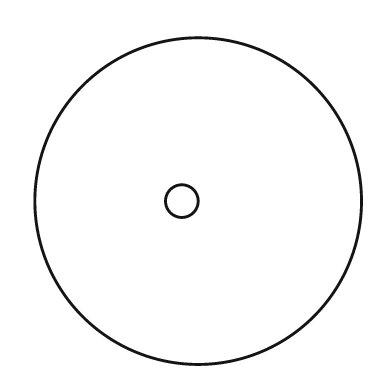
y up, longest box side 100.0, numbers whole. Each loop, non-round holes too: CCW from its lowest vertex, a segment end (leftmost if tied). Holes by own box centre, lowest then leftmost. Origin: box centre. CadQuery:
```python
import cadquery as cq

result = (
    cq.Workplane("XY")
    .moveTo(0.0, 0.0)
    .circle(50.0)
    .moveTo(-5.0, 0.0)
    .circle(5.0)
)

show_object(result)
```